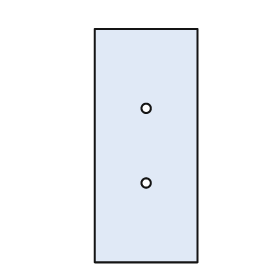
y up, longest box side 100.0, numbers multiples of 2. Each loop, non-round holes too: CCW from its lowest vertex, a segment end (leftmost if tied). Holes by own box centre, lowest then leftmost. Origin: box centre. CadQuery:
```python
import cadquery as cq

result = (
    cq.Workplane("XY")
    .moveTo(-22.0, -50.0)
    .lineTo(22.0, -50.0)
    .lineTo(22.0, 50.0)
    .lineTo(-22.0, 50.0)
    .close()
    .moveTo(0.0, -16.0)
    .circle(2.0)
    .moveTo(0.0, 16.0)
    .circle(2.0)
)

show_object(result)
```